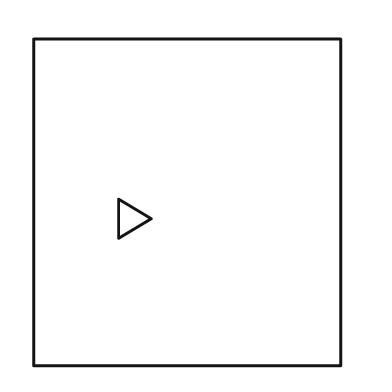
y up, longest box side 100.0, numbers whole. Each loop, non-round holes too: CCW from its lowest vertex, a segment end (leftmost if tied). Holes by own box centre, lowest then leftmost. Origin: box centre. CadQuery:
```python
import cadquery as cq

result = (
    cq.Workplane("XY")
    .moveTo(-47.0, -50.0)
    .lineTo(47.0, -50.0)
    .lineTo(47.0, 50.0)
    .lineTo(-47.0, 50.0)
    .close()
    .moveTo(-21.0, -11.0)
    .lineTo(-11.0, -5.0)
    .lineTo(-21.0, 1.0)
    .close()
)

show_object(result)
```